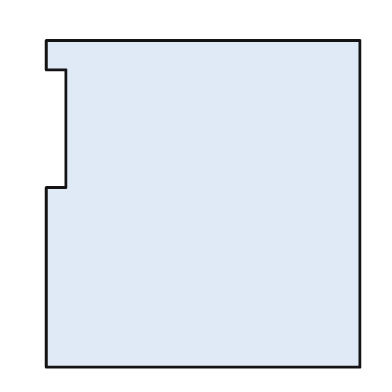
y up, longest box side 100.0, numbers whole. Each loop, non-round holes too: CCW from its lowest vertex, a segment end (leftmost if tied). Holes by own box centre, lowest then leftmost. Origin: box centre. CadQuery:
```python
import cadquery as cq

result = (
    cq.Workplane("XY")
    .moveTo(-48.0, -50.0)
    .lineTo(48.0, -50.0)
    .lineTo(48.0, 50.0)
    .lineTo(-48.0, 50.0)
    .lineTo(-48.0, 41.0)
    .lineTo(-42.0, 41.0)
    .lineTo(-42.0, 5.0)
    .lineTo(-48.0, 5.0)
    .close()
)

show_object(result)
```